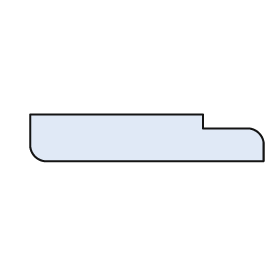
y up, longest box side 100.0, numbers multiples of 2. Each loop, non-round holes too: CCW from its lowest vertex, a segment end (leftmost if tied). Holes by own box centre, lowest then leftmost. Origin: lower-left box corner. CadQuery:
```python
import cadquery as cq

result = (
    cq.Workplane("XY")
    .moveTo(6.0, 0.0)
    .lineTo(100.0, 0.0)
    .lineTo(100.0, 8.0)
    .threePointArc((98.0, 12.0), (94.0, 14.0))
    .lineTo(74.0, 14.0)
    .lineTo(74.0, 20.0)
    .lineTo(0.0, 20.0)
    .lineTo(0.0, 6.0)
    .threePointArc((2.0, 2.0), (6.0, 0.0))
    .close()
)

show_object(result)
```